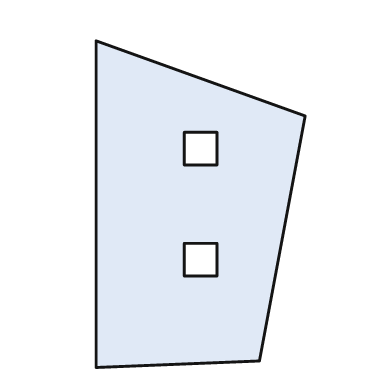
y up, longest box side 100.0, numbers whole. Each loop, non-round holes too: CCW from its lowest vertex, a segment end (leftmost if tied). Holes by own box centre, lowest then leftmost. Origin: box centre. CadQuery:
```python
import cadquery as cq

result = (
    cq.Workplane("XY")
    .moveTo(-32.0, -50.0)
    .lineTo(18.0, -48.0)
    .lineTo(32.0, 27.0)
    .lineTo(-32.0, 50.0)
    .close()
    .moveTo(-5.0, -22.0)
    .lineTo(5.0, -22.0)
    .lineTo(5.0, -12.0)
    .lineTo(-5.0, -12.0)
    .close()
    .moveTo(-5.0, 12.0)
    .lineTo(5.0, 12.0)
    .lineTo(5.0, 22.0)
    .lineTo(-5.0, 22.0)
    .close()
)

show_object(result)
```